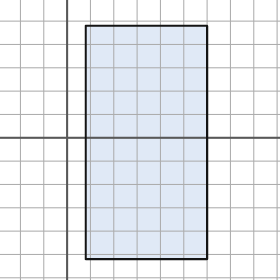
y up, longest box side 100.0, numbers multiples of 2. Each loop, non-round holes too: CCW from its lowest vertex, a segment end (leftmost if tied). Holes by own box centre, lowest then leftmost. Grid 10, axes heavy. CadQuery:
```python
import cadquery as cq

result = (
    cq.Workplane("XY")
    .moveTo(8.0, -52.0)
    .lineTo(60.0, -52.0)
    .lineTo(60.0, 48.0)
    .lineTo(8.0, 48.0)
    .close()
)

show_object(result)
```